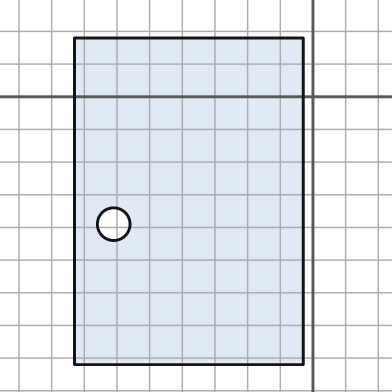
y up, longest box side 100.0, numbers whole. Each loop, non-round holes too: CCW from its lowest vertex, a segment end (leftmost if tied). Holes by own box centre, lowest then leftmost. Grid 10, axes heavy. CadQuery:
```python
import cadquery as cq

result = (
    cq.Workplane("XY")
    .moveTo(-73.0, -82.0)
    .lineTo(-3.0, -82.0)
    .lineTo(-3.0, 18.0)
    .lineTo(-73.0, 18.0)
    .close()
    .moveTo(-61.0, -39.0)
    .circle(5.0)
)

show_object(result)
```